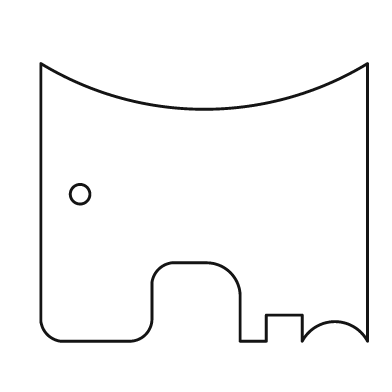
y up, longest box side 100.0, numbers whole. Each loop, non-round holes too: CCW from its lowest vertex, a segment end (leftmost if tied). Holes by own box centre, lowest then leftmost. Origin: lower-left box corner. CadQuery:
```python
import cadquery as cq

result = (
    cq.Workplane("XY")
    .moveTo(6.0, 0.0)
    .lineTo(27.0, 0.0)
    .threePointArc((32.0, 2.0), (34.0, 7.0))
    .lineTo(34.0, 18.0)
    .threePointArc((36.0, 22.0), (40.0, 24.0))
    .lineTo(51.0, 24.0)
    .threePointArc((58.0, 21.0), (61.0, 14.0))
    .lineTo(61.0, 0.0)
    .lineTo(69.0, 0.0)
    .lineTo(69.0, 8.0)
    .lineTo(80.0, 8.0)
    .lineTo(80.0, 0.0)
    .threePointArc((90.0, 6.0), (100.0, 0.0))
    .lineTo(100.0, 85.0)
    .threePointArc((50.0, 71.0), (0.0, 85.0))
    .lineTo(0.0, 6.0)
    .threePointArc((2.0, 2.0), (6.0, 0.0))
    .close()
    .moveTo(12.0, 45.0)
    .circle(3.0)
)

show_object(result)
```